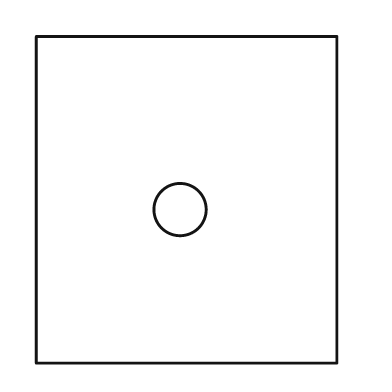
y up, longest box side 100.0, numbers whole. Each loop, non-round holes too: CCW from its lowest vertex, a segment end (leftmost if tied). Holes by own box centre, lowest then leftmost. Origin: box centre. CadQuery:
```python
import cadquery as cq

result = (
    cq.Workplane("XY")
    .moveTo(-46.0, -50.0)
    .lineTo(46.0, -50.0)
    .lineTo(46.0, 50.0)
    .lineTo(-46.0, 50.0)
    .close()
    .moveTo(-2.0, -3.0)
    .circle(8.0)
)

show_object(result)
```